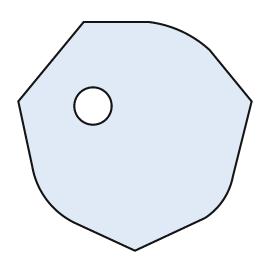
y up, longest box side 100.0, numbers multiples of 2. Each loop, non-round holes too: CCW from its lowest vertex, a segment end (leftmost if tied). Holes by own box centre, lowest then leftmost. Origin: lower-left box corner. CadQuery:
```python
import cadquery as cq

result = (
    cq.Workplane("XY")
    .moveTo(50.0, 0.0)
    .lineTo(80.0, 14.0)
    .threePointArc((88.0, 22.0), (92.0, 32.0))
    .lineTo(100.0, 64.0)
    .lineTo(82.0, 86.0)
    .threePointArc((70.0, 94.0), (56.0, 98.0))
    .lineTo(28.0, 98.0)
    .lineTo(0.0, 64.0)
    .lineTo(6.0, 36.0)
    .threePointArc((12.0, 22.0), (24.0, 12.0))
    .close()
    .moveTo(32.0, 62.0)
    .circle(8.0)
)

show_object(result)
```